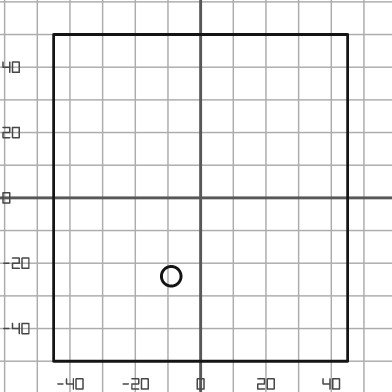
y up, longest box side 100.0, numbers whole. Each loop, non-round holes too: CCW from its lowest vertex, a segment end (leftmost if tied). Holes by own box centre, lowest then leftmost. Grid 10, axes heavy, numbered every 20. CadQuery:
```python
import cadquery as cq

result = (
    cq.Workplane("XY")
    .moveTo(-45.0, -50.0)
    .lineTo(45.0, -50.0)
    .lineTo(45.0, 50.0)
    .lineTo(-45.0, 50.0)
    .close()
    .moveTo(-9.0, -24.0)
    .circle(3.0)
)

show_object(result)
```